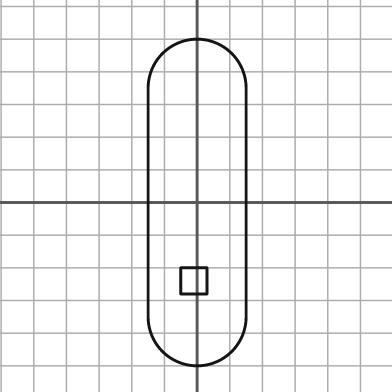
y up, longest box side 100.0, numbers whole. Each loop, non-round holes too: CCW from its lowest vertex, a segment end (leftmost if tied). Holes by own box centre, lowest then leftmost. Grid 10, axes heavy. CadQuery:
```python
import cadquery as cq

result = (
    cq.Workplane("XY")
    .moveTo(-15.0, -35.0)
    .threePointArc((0.0, -50.0), (15.0, -35.0))
    .lineTo(15.0, 35.0)
    .threePointArc((0.0, 50.0), (-15.0, 35.0))
    .close()
    .moveTo(-5.0, -28.0)
    .lineTo(3.0, -28.0)
    .lineTo(3.0, -20.0)
    .lineTo(-5.0, -20.0)
    .close()
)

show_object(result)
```